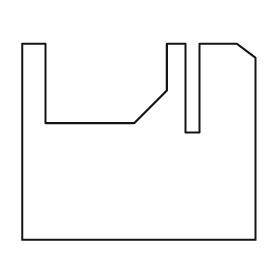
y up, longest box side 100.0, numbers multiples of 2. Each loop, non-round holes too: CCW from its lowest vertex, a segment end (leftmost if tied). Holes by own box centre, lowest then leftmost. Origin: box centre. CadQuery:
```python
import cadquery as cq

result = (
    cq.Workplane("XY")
    .moveTo(-50.0, -42.0)
    .lineTo(50.0, -42.0)
    .lineTo(50.0, 36.0)
    .lineTo(42.0, 42.0)
    .lineTo(26.0, 42.0)
    .lineTo(26.0, 4.0)
    .lineTo(20.0, 4.0)
    .lineTo(20.0, 42.0)
    .lineTo(12.0, 42.0)
    .lineTo(12.0, 22.0)
    .lineTo(-2.0, 8.0)
    .lineTo(-40.0, 8.0)
    .lineTo(-40.0, 42.0)
    .lineTo(-50.0, 42.0)
    .close()
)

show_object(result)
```